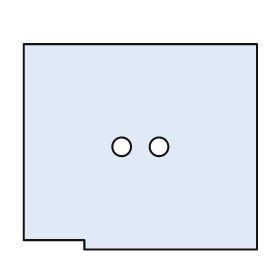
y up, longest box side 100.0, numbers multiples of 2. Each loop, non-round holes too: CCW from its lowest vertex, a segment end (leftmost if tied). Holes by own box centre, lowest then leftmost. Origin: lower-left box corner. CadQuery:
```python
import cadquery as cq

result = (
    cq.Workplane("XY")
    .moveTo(26.0, 0.0)
    .lineTo(100.0, 0.0)
    .lineTo(100.0, 88.0)
    .lineTo(0.0, 88.0)
    .lineTo(0.0, 4.0)
    .lineTo(26.0, 4.0)
    .close()
    .moveTo(42.0, 44.0)
    .circle(4.0)
    .moveTo(58.0, 44.0)
    .circle(4.0)
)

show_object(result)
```